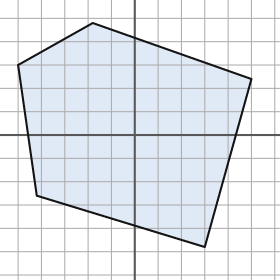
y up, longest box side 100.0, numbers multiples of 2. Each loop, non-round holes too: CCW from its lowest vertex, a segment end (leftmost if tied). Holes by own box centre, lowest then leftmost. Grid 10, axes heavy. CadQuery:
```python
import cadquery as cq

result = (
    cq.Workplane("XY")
    .moveTo(30.0, -48.0)
    .lineTo(50.0, 24.0)
    .lineTo(-18.0, 48.0)
    .lineTo(-50.0, 30.0)
    .lineTo(-42.0, -26.0)
    .close()
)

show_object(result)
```